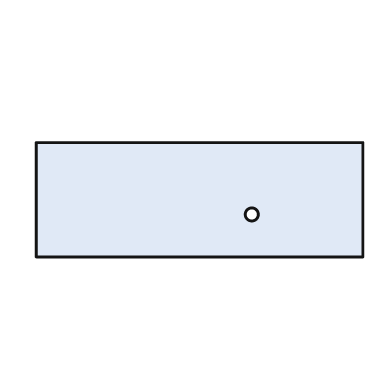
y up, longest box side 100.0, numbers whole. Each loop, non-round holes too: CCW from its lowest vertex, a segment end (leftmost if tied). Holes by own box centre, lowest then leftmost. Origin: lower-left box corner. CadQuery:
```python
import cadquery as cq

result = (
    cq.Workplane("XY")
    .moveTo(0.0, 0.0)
    .lineTo(100.0, 0.0)
    .lineTo(100.0, 35.0)
    .lineTo(0.0, 35.0)
    .close()
    .moveTo(66.0, 13.0)
    .circle(2.0)
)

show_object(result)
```